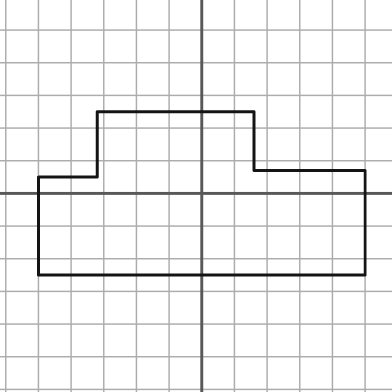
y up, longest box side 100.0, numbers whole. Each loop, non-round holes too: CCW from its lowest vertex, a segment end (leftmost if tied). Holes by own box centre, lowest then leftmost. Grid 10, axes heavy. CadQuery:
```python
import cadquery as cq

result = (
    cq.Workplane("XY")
    .moveTo(-50.0, -25.0)
    .lineTo(50.0, -25.0)
    .lineTo(50.0, 7.0)
    .lineTo(16.0, 7.0)
    .lineTo(16.0, 25.0)
    .lineTo(-32.0, 25.0)
    .lineTo(-32.0, 5.0)
    .lineTo(-50.0, 5.0)
    .close()
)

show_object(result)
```